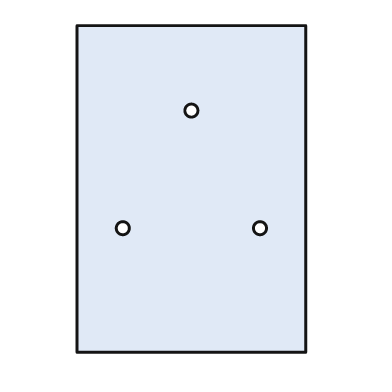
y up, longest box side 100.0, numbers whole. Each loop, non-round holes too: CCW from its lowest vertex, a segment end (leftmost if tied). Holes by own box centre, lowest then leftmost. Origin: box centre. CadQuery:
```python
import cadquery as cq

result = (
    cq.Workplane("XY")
    .moveTo(-35.0, -50.0)
    .lineTo(35.0, -50.0)
    .lineTo(35.0, 50.0)
    .lineTo(-35.0, 50.0)
    .close()
    .moveTo(-21.0, -12.0)
    .circle(2.0)
    .moveTo(21.0, -12.0)
    .circle(2.0)
    .moveTo(0.0, 24.0)
    .circle(2.0)
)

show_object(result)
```